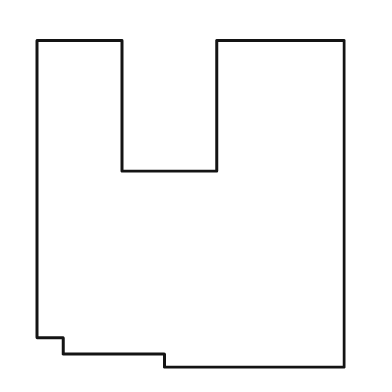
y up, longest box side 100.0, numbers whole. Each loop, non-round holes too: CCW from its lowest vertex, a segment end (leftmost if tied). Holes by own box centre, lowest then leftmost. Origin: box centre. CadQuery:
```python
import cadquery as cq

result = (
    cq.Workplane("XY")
    .moveTo(-8.0, -50.0)
    .lineTo(47.0, -50.0)
    .lineTo(47.0, 50.0)
    .lineTo(8.0, 50.0)
    .lineTo(8.0, 10.0)
    .lineTo(-21.0, 10.0)
    .lineTo(-21.0, 50.0)
    .lineTo(-47.0, 50.0)
    .lineTo(-47.0, -41.0)
    .lineTo(-39.0, -41.0)
    .lineTo(-39.0, -46.0)
    .lineTo(-8.0, -46.0)
    .close()
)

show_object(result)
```